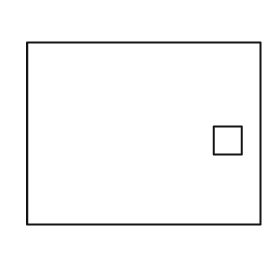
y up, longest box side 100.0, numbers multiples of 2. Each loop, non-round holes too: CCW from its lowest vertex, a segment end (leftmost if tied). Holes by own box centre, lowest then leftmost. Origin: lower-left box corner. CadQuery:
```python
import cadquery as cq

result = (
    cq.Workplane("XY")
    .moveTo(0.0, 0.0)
    .lineTo(100.0, 0.0)
    .lineTo(100.0, 78.0)
    .lineTo(0.0, 78.0)
    .close()
    .moveTo(80.0, 30.0)
    .lineTo(92.0, 30.0)
    .lineTo(92.0, 42.0)
    .lineTo(80.0, 42.0)
    .close()
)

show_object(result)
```